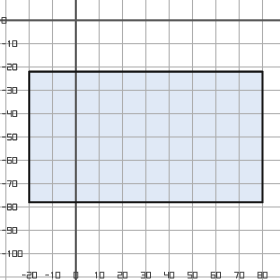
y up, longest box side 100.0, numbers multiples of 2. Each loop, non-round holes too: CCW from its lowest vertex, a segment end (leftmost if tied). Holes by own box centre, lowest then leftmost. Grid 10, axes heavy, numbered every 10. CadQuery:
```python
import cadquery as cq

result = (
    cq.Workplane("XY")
    .moveTo(-20.0, -78.0)
    .lineTo(80.0, -78.0)
    .lineTo(80.0, -22.0)
    .lineTo(-20.0, -22.0)
    .close()
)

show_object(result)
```